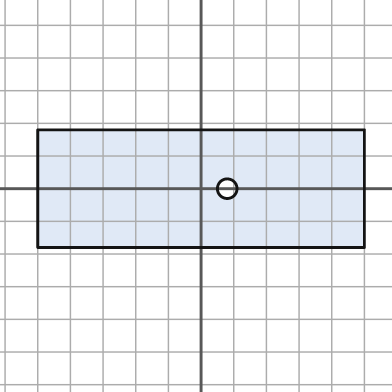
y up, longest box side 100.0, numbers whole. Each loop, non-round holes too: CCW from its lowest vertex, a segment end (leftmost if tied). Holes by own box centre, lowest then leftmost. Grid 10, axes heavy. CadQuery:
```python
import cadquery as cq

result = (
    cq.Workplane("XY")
    .moveTo(-50.0, -18.0)
    .lineTo(50.0, -18.0)
    .lineTo(50.0, 18.0)
    .lineTo(-50.0, 18.0)
    .close()
    .moveTo(8.0, 0.0)
    .circle(3.0)
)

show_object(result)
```